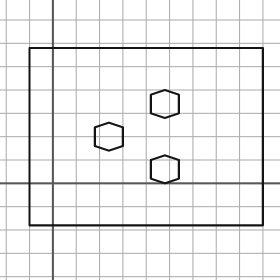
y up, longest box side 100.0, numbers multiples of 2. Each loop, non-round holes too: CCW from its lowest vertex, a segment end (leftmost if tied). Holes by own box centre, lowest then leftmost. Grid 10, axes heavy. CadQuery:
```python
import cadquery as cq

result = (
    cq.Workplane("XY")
    .moveTo(-10.0, -18.0)
    .lineTo(90.0, -18.0)
    .lineTo(90.0, 58.0)
    .lineTo(-10.0, 58.0)
    .close()
    .moveTo(48.0, 0.0)
    .lineTo(54.0, 2.0)
    .lineTo(54.0, 10.0)
    .lineTo(48.0, 12.0)
    .lineTo(42.0, 10.0)
    .lineTo(42.0, 2.0)
    .close()
    .moveTo(24.0, 14.0)
    .lineTo(30.0, 16.0)
    .lineTo(30.0, 24.0)
    .lineTo(24.0, 26.0)
    .lineTo(18.0, 24.0)
    .lineTo(18.0, 16.0)
    .close()
    .moveTo(48.0, 28.0)
    .lineTo(54.0, 30.0)
    .lineTo(54.0, 38.0)
    .lineTo(48.0, 40.0)
    .lineTo(42.0, 38.0)
    .lineTo(42.0, 30.0)
    .close()
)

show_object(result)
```